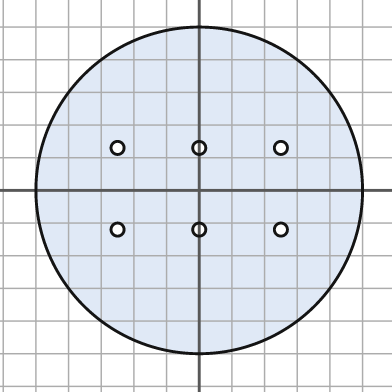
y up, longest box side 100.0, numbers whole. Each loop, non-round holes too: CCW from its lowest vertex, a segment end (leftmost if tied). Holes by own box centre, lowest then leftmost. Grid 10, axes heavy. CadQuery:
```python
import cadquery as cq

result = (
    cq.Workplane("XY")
    .moveTo(0.0, 0.0)
    .circle(50.0)
    .moveTo(-25.0, -12.0)
    .circle(2.0)
    .moveTo(0.0, -12.0)
    .circle(2.0)
    .moveTo(25.0, -12.0)
    .circle(2.0)
    .moveTo(-25.0, 13.0)
    .circle(2.0)
    .moveTo(0.0, 13.0)
    .circle(2.0)
    .moveTo(25.0, 13.0)
    .circle(2.0)
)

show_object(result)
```